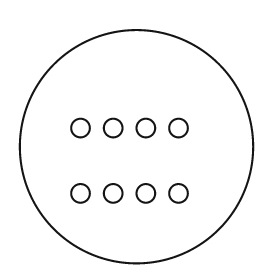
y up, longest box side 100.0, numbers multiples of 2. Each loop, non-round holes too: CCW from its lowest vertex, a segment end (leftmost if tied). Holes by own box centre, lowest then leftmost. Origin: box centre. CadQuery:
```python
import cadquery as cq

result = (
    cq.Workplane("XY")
    .moveTo(0.0, 0.0)
    .circle(50.0)
    .moveTo(-24.0, -20.0)
    .circle(4.0)
    .moveTo(-10.0, -20.0)
    .circle(4.0)
    .moveTo(4.0, -20.0)
    .circle(4.0)
    .moveTo(18.0, -20.0)
    .circle(4.0)
    .moveTo(-24.0, 8.0)
    .circle(4.0)
    .moveTo(-10.0, 8.0)
    .circle(4.0)
    .moveTo(4.0, 8.0)
    .circle(4.0)
    .moveTo(18.0, 8.0)
    .circle(4.0)
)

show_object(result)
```